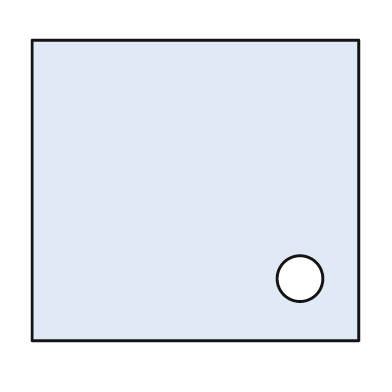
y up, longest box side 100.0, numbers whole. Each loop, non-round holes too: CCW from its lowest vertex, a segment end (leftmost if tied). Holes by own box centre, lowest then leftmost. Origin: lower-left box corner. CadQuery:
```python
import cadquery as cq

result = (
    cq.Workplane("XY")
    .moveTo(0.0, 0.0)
    .lineTo(100.0, 0.0)
    .lineTo(100.0, 92.0)
    .lineTo(0.0, 92.0)
    .close()
    .moveTo(82.0, 19.0)
    .circle(7.0)
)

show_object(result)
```